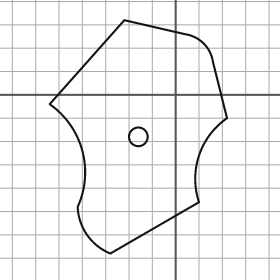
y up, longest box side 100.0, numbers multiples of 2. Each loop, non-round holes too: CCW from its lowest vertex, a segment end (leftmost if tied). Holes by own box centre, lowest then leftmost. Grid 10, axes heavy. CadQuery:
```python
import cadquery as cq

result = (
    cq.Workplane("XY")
    .moveTo(-28.0, -68.0)
    .lineTo(10.0, -46.0)
    .threePointArc((10.0, -26.0), (22.0, -10.0))
    .lineTo(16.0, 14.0)
    .threePointArc((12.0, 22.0), (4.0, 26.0))
    .lineTo(-22.0, 32.0)
    .lineTo(-54.0, -4.0)
    .threePointArc((-40.0, -24.0), (-42.0, -48.0))
    .threePointArc((-38.0, -60.0), (-28.0, -68.0))
    .close()
    .moveTo(-16.0, -18.0)
    .circle(4.0)
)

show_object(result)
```